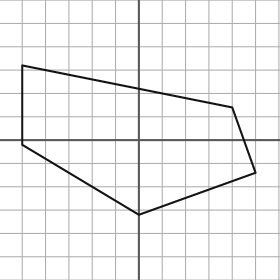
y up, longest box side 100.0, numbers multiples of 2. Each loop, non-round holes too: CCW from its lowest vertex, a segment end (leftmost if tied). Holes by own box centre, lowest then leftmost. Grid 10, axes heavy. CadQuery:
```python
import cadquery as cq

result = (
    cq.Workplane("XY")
    .moveTo(0.0, -32.0)
    .lineTo(50.0, -14.0)
    .lineTo(40.0, 14.0)
    .lineTo(-50.0, 32.0)
    .lineTo(-50.0, -2.0)
    .close()
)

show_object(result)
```